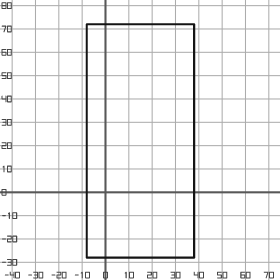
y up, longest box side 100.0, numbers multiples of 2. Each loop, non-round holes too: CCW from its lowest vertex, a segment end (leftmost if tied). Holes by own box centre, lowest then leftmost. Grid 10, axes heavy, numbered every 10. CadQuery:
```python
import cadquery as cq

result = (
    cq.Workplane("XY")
    .moveTo(-8.0, -28.0)
    .lineTo(38.0, -28.0)
    .lineTo(38.0, 72.0)
    .lineTo(-8.0, 72.0)
    .close()
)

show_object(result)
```